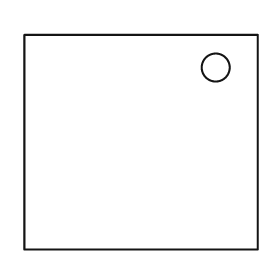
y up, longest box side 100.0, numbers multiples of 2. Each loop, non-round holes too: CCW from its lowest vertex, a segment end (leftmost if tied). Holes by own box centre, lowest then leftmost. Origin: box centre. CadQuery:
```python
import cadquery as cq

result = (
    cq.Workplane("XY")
    .moveTo(-50.0, -46.0)
    .lineTo(50.0, -46.0)
    .lineTo(50.0, 46.0)
    .lineTo(-50.0, 46.0)
    .close()
    .moveTo(32.0, 32.0)
    .circle(6.0)
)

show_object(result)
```